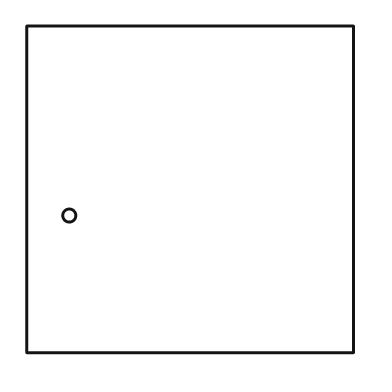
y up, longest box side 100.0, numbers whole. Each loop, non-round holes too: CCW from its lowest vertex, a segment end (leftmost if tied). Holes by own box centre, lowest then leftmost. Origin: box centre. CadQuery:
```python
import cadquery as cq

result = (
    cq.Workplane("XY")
    .moveTo(-50.0, -50.0)
    .lineTo(50.0, -50.0)
    .lineTo(50.0, 50.0)
    .lineTo(-50.0, 50.0)
    .close()
    .moveTo(-37.0, -8.0)
    .circle(2.0)
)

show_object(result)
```